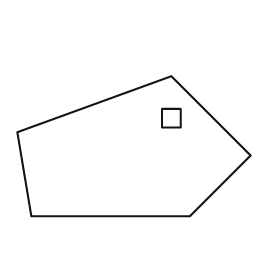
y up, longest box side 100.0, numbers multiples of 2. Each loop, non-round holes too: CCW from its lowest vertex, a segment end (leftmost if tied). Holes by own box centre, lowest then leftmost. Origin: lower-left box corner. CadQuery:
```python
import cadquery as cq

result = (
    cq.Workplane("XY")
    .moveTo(6.0, 0.0)
    .lineTo(74.0, 0.0)
    .lineTo(100.0, 26.0)
    .lineTo(66.0, 60.0)
    .lineTo(0.0, 36.0)
    .close()
    .moveTo(62.0, 38.0)
    .lineTo(70.0, 38.0)
    .lineTo(70.0, 46.0)
    .lineTo(62.0, 46.0)
    .close()
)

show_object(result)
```